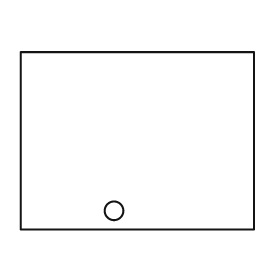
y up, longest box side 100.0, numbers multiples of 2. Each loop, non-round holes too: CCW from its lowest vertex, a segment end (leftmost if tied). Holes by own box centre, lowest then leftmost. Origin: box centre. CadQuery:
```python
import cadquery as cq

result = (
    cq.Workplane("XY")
    .moveTo(-50.0, -38.0)
    .lineTo(50.0, -38.0)
    .lineTo(50.0, 38.0)
    .lineTo(-50.0, 38.0)
    .close()
    .moveTo(-10.0, -30.0)
    .circle(4.0)
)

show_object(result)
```